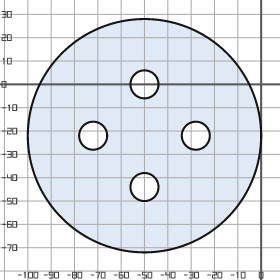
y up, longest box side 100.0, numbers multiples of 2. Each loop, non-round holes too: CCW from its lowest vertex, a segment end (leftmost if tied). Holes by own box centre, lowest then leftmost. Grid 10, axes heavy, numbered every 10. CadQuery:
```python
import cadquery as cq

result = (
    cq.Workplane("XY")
    .moveTo(-50.0, -22.0)
    .circle(50.0)
    .moveTo(-50.0, -44.0)
    .circle(6.0)
    .moveTo(-72.0, -22.0)
    .circle(6.0)
    .moveTo(-28.0, -22.0)
    .circle(6.0)
    .moveTo(-50.0, 0.0)
    .circle(6.0)
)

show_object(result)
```